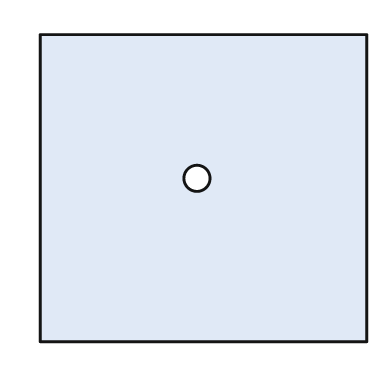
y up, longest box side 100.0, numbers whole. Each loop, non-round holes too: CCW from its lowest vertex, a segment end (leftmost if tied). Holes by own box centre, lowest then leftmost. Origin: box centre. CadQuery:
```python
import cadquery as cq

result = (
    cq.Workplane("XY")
    .moveTo(-50.0, -47.0)
    .lineTo(50.0, -47.0)
    .lineTo(50.0, 47.0)
    .lineTo(-50.0, 47.0)
    .close()
    .moveTo(-2.0, 3.0)
    .circle(4.0)
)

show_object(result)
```